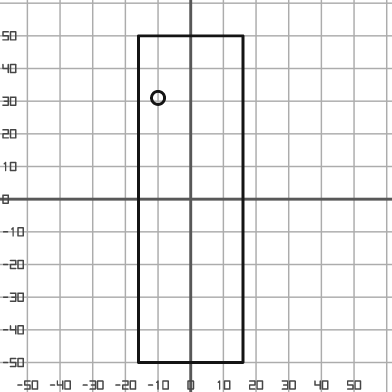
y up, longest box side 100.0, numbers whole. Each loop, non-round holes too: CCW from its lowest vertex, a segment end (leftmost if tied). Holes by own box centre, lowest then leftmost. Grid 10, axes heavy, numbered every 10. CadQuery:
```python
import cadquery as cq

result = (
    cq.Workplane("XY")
    .moveTo(-16.0, -50.0)
    .lineTo(16.0, -50.0)
    .lineTo(16.0, 50.0)
    .lineTo(-16.0, 50.0)
    .close()
    .moveTo(-10.0, 31.0)
    .circle(2.0)
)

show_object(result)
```